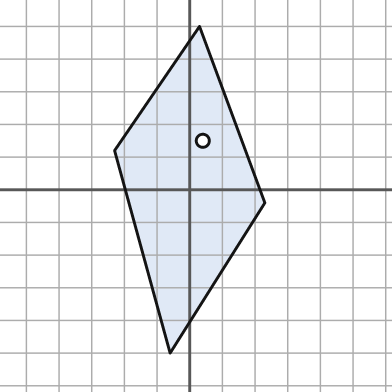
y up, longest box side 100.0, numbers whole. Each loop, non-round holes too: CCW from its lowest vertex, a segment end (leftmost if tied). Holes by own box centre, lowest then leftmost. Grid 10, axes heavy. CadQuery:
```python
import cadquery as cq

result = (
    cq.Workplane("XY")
    .moveTo(-6.0, -50.0)
    .lineTo(23.0, -4.0)
    .lineTo(3.0, 50.0)
    .lineTo(-23.0, 12.0)
    .close()
    .moveTo(4.0, 15.0)
    .circle(2.0)
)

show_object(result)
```